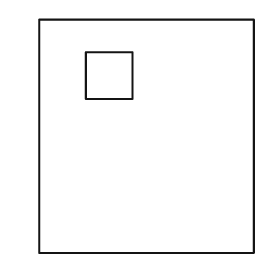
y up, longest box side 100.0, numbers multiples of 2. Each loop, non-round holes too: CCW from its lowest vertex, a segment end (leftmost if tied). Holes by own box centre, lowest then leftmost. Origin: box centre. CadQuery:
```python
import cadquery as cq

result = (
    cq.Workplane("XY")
    .moveTo(-46.0, -50.0)
    .lineTo(46.0, -50.0)
    .lineTo(46.0, 50.0)
    .lineTo(-46.0, 50.0)
    .close()
    .moveTo(-26.0, 16.0)
    .lineTo(-6.0, 16.0)
    .lineTo(-6.0, 36.0)
    .lineTo(-26.0, 36.0)
    .close()
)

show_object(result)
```